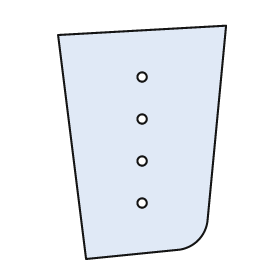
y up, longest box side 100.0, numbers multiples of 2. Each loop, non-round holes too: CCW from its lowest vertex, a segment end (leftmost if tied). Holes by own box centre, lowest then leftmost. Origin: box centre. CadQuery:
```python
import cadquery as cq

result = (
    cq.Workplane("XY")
    .moveTo(-24.0, -50.0)
    .lineTo(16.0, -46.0)
    .threePointArc((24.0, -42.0), (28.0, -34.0))
    .lineTo(36.0, 50.0)
    .lineTo(-36.0, 46.0)
    .close()
    .moveTo(0.0, -26.0)
    .circle(2.0)
    .moveTo(0.0, -8.0)
    .circle(2.0)
    .moveTo(0.0, 10.0)
    .circle(2.0)
    .moveTo(0.0, 28.0)
    .circle(2.0)
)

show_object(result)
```